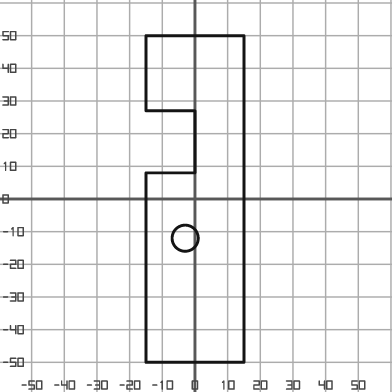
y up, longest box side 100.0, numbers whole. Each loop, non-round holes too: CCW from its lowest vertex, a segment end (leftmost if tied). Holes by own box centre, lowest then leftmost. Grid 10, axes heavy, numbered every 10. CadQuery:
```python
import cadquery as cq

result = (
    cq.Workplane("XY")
    .moveTo(-15.0, -50.0)
    .lineTo(15.0, -50.0)
    .lineTo(15.0, 50.0)
    .lineTo(-15.0, 50.0)
    .lineTo(-15.0, 27.0)
    .lineTo(0.0, 27.0)
    .lineTo(0.0, 8.0)
    .lineTo(-15.0, 8.0)
    .close()
    .moveTo(-3.0, -12.0)
    .circle(4.0)
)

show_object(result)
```